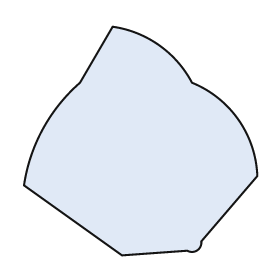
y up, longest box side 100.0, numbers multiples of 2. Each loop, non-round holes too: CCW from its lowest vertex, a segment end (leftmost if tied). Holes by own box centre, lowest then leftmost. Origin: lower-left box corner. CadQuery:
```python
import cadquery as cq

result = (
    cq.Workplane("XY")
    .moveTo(42.0, 0.0)
    .lineTo(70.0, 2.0)
    .threePointArc((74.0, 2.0), (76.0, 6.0))
    .lineTo(100.0, 34.0)
    .threePointArc((92.0, 58.0), (72.0, 74.0))
    .threePointArc((58.0, 90.0), (38.0, 98.0))
    .lineTo(24.0, 74.0)
    .threePointArc((8.0, 54.0), (0.0, 30.0))
    .close()
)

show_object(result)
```